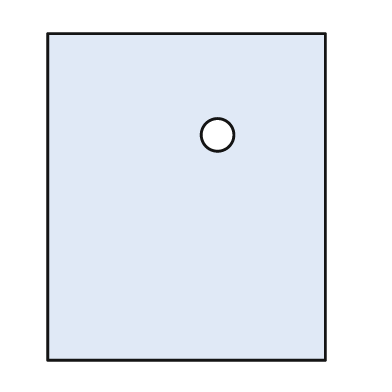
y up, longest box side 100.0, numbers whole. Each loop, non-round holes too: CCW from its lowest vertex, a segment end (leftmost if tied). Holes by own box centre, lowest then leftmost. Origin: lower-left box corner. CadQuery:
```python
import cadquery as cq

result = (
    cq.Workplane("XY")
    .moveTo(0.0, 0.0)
    .lineTo(85.0, 0.0)
    .lineTo(85.0, 100.0)
    .lineTo(0.0, 100.0)
    .close()
    .moveTo(52.0, 69.0)
    .circle(5.0)
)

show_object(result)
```